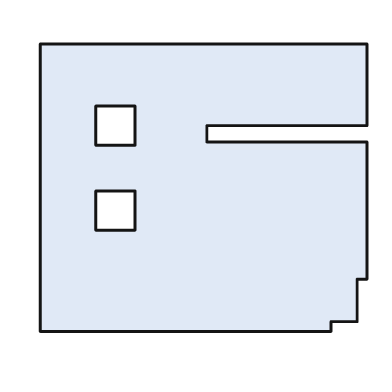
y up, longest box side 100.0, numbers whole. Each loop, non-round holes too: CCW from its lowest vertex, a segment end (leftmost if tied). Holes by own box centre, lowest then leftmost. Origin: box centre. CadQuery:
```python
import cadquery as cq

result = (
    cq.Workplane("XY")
    .moveTo(-50.0, -44.0)
    .lineTo(39.0, -44.0)
    .lineTo(39.0, -41.0)
    .lineTo(47.0, -41.0)
    .lineTo(47.0, -28.0)
    .lineTo(50.0, -28.0)
    .lineTo(50.0, 14.0)
    .lineTo(1.0, 14.0)
    .lineTo(1.0, 19.0)
    .lineTo(50.0, 19.0)
    .lineTo(50.0, 44.0)
    .lineTo(-50.0, 44.0)
    .close()
    .moveTo(-33.0, -13.0)
    .lineTo(-21.0, -13.0)
    .lineTo(-21.0, -1.0)
    .lineTo(-33.0, -1.0)
    .close()
    .moveTo(-33.0, 13.0)
    .lineTo(-21.0, 13.0)
    .lineTo(-21.0, 25.0)
    .lineTo(-33.0, 25.0)
    .close()
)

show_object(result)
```